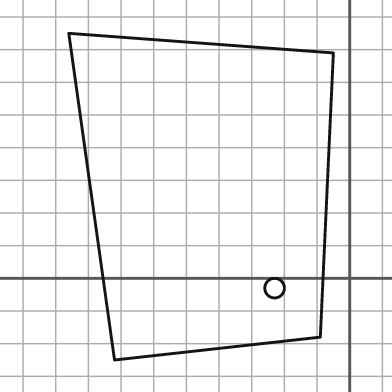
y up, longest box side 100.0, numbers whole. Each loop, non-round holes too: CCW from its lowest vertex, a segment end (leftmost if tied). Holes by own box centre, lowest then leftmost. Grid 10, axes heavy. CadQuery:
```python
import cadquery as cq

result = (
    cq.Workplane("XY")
    .moveTo(-72.0, -25.0)
    .lineTo(-9.0, -18.0)
    .lineTo(-5.0, 69.0)
    .lineTo(-86.0, 75.0)
    .close()
    .moveTo(-23.0, -3.0)
    .circle(3.0)
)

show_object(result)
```